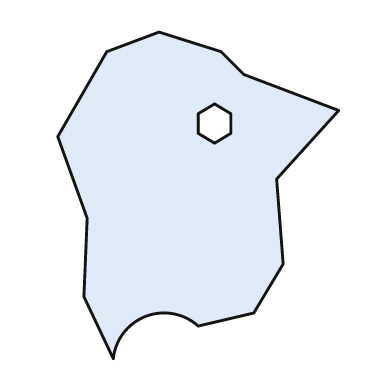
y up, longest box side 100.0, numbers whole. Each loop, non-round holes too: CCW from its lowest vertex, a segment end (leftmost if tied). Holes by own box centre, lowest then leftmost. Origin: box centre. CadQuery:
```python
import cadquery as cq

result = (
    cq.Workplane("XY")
    .moveTo(-26.0, -50.0)
    .threePointArc((-16.0, -37.0), (0.0, -40.0))
    .lineTo(17.0, -36.0)
    .lineTo(26.0, -21.0)
    .lineTo(24.0, 5.0)
    .lineTo(43.0, 26.0)
    .lineTo(14.0, 37.0)
    .lineTo(7.0, 44.0)
    .lineTo(-12.0, 50.0)
    .lineTo(-28.0, 44.0)
    .lineTo(-43.0, 18.0)
    .lineTo(-34.0, -7.0)
    .lineTo(-35.0, -31.0)
    .close()
    .moveTo(5.0, 16.0)
    .lineTo(10.0, 19.0)
    .lineTo(10.0, 25.0)
    .lineTo(5.0, 28.0)
    .lineTo(0.0, 25.0)
    .lineTo(0.0, 19.0)
    .close()
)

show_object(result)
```